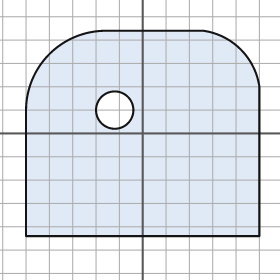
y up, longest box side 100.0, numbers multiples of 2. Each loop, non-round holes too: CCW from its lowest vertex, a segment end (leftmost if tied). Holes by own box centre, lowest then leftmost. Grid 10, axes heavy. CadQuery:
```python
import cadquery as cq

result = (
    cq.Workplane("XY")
    .moveTo(-50.0, -44.0)
    .lineTo(50.0, -44.0)
    .lineTo(50.0, 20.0)
    .threePointArc((42.0, 36.0), (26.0, 44.0))
    .lineTo(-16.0, 44.0)
    .threePointArc((-40.0, 34.0), (-50.0, 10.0))
    .close()
    .moveTo(-12.0, 10.0)
    .circle(8.0)
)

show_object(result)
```